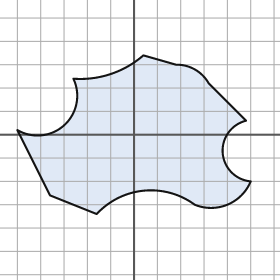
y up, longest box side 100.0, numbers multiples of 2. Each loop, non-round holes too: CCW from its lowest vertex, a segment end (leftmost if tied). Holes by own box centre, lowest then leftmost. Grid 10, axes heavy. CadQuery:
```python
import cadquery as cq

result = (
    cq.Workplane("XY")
    .moveTo(-16.0, -34.0)
    .threePointArc((4.0, -24.0), (26.0, -30.0))
    .threePointArc((40.0, -30.0), (50.0, -20.0))
    .threePointArc((38.0, -8.0), (48.0, 6.0))
    .lineTo(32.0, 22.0)
    .threePointArc((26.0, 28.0), (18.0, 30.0))
    .lineTo(4.0, 34.0)
    .threePointArc((-10.0, 26.0), (-26.0, 24.0))
    .threePointArc((-30.0, 4.0), (-50.0, 2.0))
    .lineTo(-36.0, -26.0)
    .close()
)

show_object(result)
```